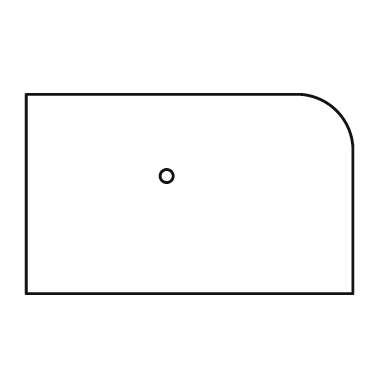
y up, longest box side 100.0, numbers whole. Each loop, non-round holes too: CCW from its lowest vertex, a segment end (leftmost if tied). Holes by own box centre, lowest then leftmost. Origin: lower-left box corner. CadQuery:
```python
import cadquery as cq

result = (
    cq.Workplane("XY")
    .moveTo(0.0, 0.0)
    .lineTo(100.0, 0.0)
    .lineTo(100.0, 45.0)
    .threePointArc((95.0, 56.0), (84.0, 61.0))
    .lineTo(0.0, 61.0)
    .close()
    .moveTo(43.0, 36.0)
    .circle(2.0)
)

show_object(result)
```